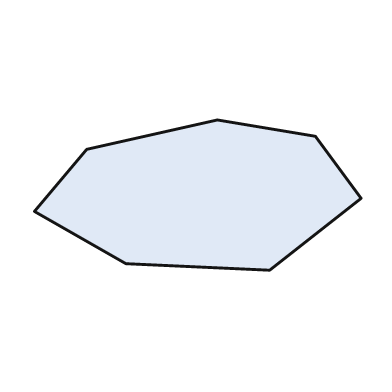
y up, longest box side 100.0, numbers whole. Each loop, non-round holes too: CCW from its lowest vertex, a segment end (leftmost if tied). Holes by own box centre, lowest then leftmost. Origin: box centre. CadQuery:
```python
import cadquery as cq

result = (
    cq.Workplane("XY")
    .moveTo(22.0, -23.0)
    .lineTo(50.0, -1.0)
    .lineTo(36.0, 18.0)
    .lineTo(6.0, 23.0)
    .lineTo(-34.0, 14.0)
    .lineTo(-50.0, -5.0)
    .lineTo(-22.0, -21.0)
    .close()
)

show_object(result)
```